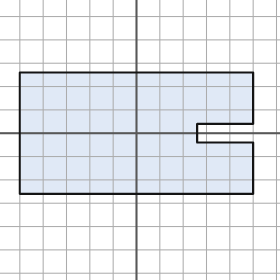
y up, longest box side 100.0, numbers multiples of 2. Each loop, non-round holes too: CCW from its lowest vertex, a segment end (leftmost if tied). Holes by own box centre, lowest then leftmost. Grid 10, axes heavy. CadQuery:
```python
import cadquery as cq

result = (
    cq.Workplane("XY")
    .moveTo(-50.0, -26.0)
    .lineTo(50.0, -26.0)
    .lineTo(50.0, -4.0)
    .lineTo(26.0, -4.0)
    .lineTo(26.0, 4.0)
    .lineTo(50.0, 4.0)
    .lineTo(50.0, 26.0)
    .lineTo(-50.0, 26.0)
    .close()
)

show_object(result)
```